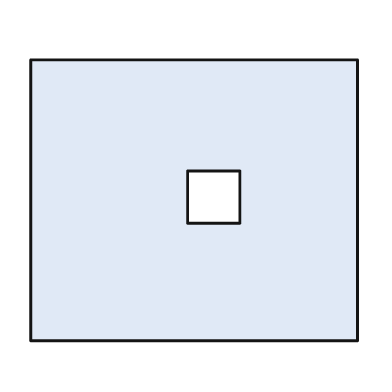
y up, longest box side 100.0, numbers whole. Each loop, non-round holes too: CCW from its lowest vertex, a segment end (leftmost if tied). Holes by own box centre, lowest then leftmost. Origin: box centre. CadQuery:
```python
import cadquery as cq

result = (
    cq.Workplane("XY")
    .moveTo(-50.0, -43.0)
    .lineTo(50.0, -43.0)
    .lineTo(50.0, 43.0)
    .lineTo(-50.0, 43.0)
    .close()
    .moveTo(-2.0, -7.0)
    .lineTo(14.0, -7.0)
    .lineTo(14.0, 9.0)
    .lineTo(-2.0, 9.0)
    .close()
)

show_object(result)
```